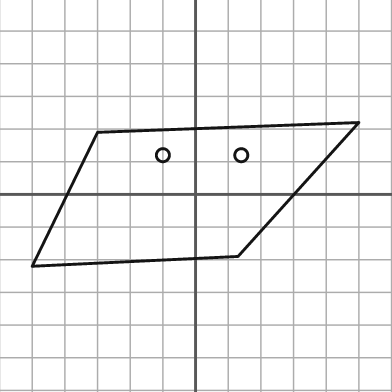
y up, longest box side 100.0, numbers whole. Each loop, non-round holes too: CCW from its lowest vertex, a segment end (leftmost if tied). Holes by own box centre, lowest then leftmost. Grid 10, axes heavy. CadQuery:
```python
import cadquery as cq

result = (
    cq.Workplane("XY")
    .moveTo(-50.0, -22.0)
    .lineTo(13.0, -19.0)
    .lineTo(50.0, 22.0)
    .lineTo(-30.0, 19.0)
    .close()
    .moveTo(-10.0, 12.0)
    .circle(2.0)
    .moveTo(14.0, 12.0)
    .circle(2.0)
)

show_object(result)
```